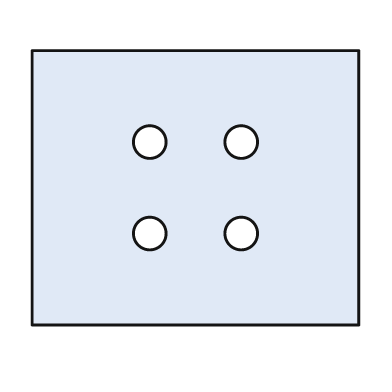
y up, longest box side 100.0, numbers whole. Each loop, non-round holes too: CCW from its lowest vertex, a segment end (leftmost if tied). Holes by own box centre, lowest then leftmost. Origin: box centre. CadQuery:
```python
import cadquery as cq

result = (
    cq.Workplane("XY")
    .moveTo(-50.0, -42.0)
    .lineTo(50.0, -42.0)
    .lineTo(50.0, 42.0)
    .lineTo(-50.0, 42.0)
    .close()
    .moveTo(-14.0, -14.0)
    .circle(5.0)
    .moveTo(14.0, -14.0)
    .circle(5.0)
    .moveTo(-14.0, 14.0)
    .circle(5.0)
    .moveTo(14.0, 14.0)
    .circle(5.0)
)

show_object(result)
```